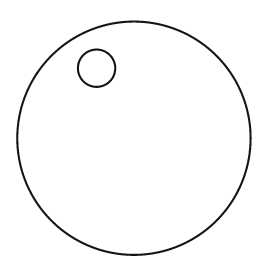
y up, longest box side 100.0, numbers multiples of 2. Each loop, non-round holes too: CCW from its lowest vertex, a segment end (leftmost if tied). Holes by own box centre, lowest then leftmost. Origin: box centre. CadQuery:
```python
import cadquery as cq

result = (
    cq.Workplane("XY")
    .moveTo(0.0, 0.0)
    .circle(50.0)
    .moveTo(-16.0, 30.0)
    .circle(8.0)
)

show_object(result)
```